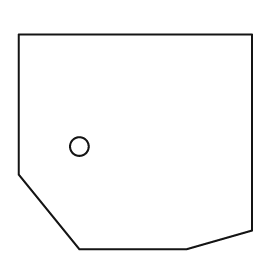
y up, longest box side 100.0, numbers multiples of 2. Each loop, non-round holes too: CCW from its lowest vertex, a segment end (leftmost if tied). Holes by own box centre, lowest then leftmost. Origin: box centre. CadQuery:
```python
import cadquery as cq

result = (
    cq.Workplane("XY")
    .moveTo(-24.0, -46.0)
    .lineTo(22.0, -46.0)
    .lineTo(50.0, -38.0)
    .lineTo(50.0, 46.0)
    .lineTo(-50.0, 46.0)
    .lineTo(-50.0, -14.0)
    .close()
    .moveTo(-24.0, -2.0)
    .circle(4.0)
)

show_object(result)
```